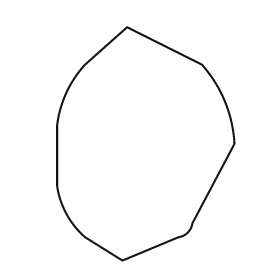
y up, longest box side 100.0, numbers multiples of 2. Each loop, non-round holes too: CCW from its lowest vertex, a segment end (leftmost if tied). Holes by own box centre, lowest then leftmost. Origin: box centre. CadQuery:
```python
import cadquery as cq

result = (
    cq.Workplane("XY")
    .moveTo(-10.0, -50.0)
    .lineTo(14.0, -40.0)
    .threePointArc((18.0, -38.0), (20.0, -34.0))
    .lineTo(38.0, 0.0)
    .threePointArc((34.0, 18.0), (24.0, 34.0))
    .lineTo(-8.0, 50.0)
    .lineTo(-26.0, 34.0)
    .threePointArc((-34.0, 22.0), (-38.0, 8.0))
    .lineTo(-38.0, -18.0)
    .threePointArc((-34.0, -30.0), (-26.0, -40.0))
    .close()
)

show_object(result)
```